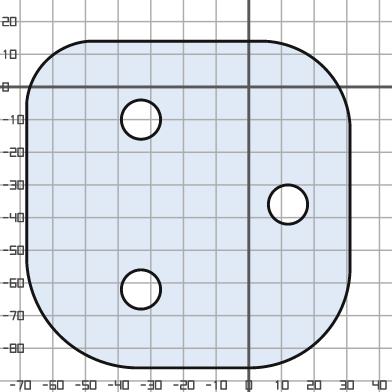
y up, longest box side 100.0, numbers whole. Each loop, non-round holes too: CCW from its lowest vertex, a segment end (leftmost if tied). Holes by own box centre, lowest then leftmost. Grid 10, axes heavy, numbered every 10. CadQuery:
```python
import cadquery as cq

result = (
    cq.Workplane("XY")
    .moveTo(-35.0, -86.0)
    .lineTo(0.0, -86.0)
    .threePointArc((22.0, -77.0), (31.0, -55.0))
    .lineTo(31.0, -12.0)
    .threePointArc((23.0, 6.0), (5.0, 14.0))
    .lineTo(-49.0, 14.0)
    .threePointArc((-62.0, 8.0), (-68.0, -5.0))
    .lineTo(-68.0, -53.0)
    .threePointArc((-58.0, -76.0), (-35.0, -86.0))
    .close()
    .moveTo(-33.0, -62.0)
    .circle(6.0)
    .moveTo(12.0, -36.0)
    .circle(6.0)
    .moveTo(-33.0, -10.0)
    .circle(6.0)
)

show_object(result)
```